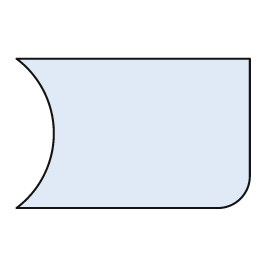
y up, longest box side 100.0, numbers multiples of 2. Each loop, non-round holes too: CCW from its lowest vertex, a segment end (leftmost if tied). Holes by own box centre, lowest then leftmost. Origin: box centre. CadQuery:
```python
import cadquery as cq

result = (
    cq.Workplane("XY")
    .moveTo(-50.0, -32.0)
    .lineTo(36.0, -32.0)
    .threePointArc((46.0, -28.0), (50.0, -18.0))
    .lineTo(50.0, 32.0)
    .lineTo(-50.0, 32.0)
    .threePointArc((-34.0, 0.0), (-50.0, -32.0))
    .close()
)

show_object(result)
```